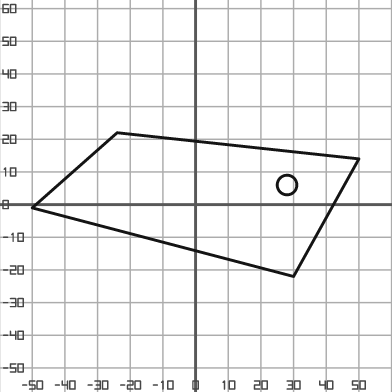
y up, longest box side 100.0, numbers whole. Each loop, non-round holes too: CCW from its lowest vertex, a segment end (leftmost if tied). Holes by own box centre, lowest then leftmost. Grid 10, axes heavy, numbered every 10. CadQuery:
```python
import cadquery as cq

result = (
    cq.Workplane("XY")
    .moveTo(30.0, -22.0)
    .lineTo(50.0, 14.0)
    .lineTo(-24.0, 22.0)
    .lineTo(-50.0, -1.0)
    .close()
    .moveTo(28.0, 6.0)
    .circle(3.0)
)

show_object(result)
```